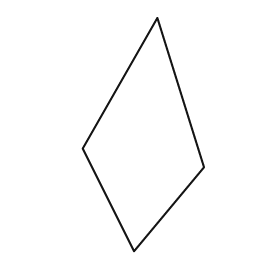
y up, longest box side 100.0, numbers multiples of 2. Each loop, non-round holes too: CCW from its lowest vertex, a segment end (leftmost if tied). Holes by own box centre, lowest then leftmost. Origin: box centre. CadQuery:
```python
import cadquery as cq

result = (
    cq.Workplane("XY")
    .moveTo(-4.0, -50.0)
    .lineTo(26.0, -14.0)
    .lineTo(6.0, 50.0)
    .lineTo(-26.0, -6.0)
    .close()
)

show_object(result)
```